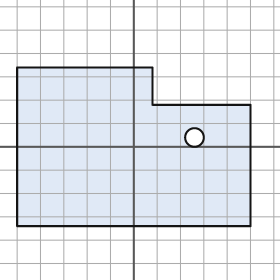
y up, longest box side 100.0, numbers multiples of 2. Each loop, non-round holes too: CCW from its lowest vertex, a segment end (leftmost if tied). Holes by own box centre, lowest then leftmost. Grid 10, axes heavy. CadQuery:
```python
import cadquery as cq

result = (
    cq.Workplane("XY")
    .moveTo(-50.0, -34.0)
    .lineTo(50.0, -34.0)
    .lineTo(50.0, 18.0)
    .lineTo(8.0, 18.0)
    .lineTo(8.0, 34.0)
    .lineTo(-50.0, 34.0)
    .close()
    .moveTo(26.0, 4.0)
    .circle(4.0)
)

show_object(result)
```